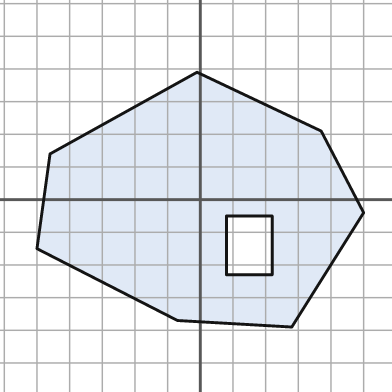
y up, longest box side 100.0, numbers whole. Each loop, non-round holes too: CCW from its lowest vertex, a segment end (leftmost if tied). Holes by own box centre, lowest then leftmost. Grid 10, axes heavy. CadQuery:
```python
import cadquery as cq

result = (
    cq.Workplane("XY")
    .moveTo(28.0, -39.0)
    .lineTo(50.0, -4.0)
    .lineTo(37.0, 21.0)
    .lineTo(-1.0, 39.0)
    .lineTo(-46.0, 14.0)
    .lineTo(-50.0, -15.0)
    .lineTo(-7.0, -37.0)
    .close()
    .moveTo(8.0, -23.0)
    .lineTo(22.0, -23.0)
    .lineTo(22.0, -5.0)
    .lineTo(8.0, -5.0)
    .close()
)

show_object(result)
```